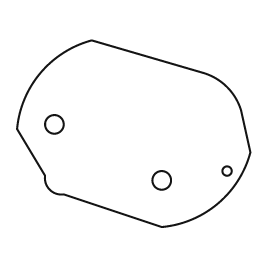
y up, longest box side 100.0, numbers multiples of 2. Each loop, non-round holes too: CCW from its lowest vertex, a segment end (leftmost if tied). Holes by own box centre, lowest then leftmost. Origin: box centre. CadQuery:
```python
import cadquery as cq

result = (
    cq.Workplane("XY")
    .moveTo(12.0, -40.0)
    .threePointArc((36.0, -30.0), (50.0, -8.0))
    .lineTo(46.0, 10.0)
    .threePointArc((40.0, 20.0), (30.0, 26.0))
    .lineTo(-18.0, 40.0)
    .threePointArc((-40.0, 26.0), (-50.0, 2.0))
    .lineTo(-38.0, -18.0)
    .threePointArc((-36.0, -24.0), (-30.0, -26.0))
    .close()
    .moveTo(12.0, -20.0)
    .circle(4.0)
    .moveTo(40.0, -16.0)
    .circle(2.0)
    .moveTo(-34.0, 4.0)
    .circle(4.0)
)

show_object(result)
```